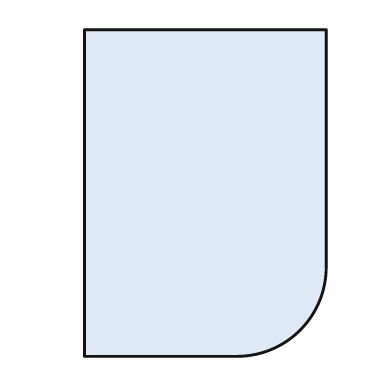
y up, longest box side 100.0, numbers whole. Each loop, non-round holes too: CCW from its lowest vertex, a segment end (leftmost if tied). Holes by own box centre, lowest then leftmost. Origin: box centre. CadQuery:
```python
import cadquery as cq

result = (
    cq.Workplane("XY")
    .moveTo(-37.0, -50.0)
    .lineTo(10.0, -50.0)
    .threePointArc((29.0, -42.0), (37.0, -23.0))
    .lineTo(37.0, 50.0)
    .lineTo(-37.0, 50.0)
    .close()
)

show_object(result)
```